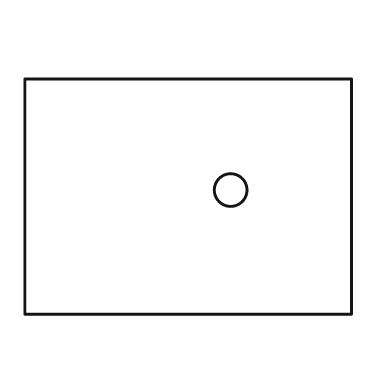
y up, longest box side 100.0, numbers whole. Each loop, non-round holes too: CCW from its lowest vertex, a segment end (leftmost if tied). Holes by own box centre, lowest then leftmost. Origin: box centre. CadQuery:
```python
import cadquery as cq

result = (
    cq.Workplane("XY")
    .moveTo(-50.0, -36.0)
    .lineTo(50.0, -36.0)
    .lineTo(50.0, 36.0)
    .lineTo(-50.0, 36.0)
    .close()
    .moveTo(13.0, 2.0)
    .circle(5.0)
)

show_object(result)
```